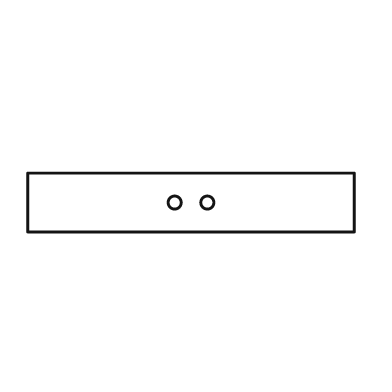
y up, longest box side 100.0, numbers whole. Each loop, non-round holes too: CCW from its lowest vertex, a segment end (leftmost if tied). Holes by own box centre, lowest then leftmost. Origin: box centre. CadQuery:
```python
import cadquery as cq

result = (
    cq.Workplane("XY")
    .moveTo(-50.0, -9.0)
    .lineTo(50.0, -9.0)
    .lineTo(50.0, 9.0)
    .lineTo(-50.0, 9.0)
    .close()
    .moveTo(-5.0, 0.0)
    .circle(2.0)
    .moveTo(5.0, 0.0)
    .circle(2.0)
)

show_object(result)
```